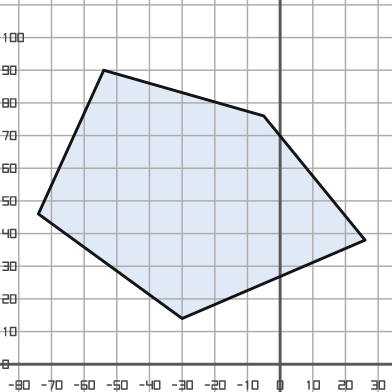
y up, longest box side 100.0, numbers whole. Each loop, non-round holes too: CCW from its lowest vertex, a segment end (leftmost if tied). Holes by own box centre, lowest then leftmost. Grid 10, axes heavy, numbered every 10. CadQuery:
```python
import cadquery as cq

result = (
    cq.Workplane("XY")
    .moveTo(-30.0, 14.0)
    .lineTo(26.0, 38.0)
    .lineTo(-5.0, 76.0)
    .lineTo(-54.0, 90.0)
    .lineTo(-74.0, 46.0)
    .close()
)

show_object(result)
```